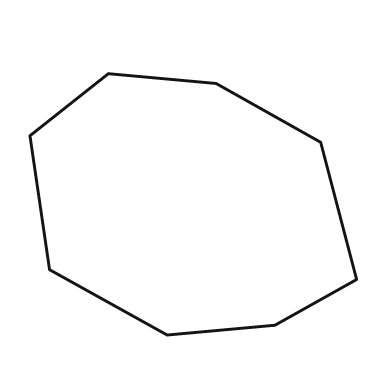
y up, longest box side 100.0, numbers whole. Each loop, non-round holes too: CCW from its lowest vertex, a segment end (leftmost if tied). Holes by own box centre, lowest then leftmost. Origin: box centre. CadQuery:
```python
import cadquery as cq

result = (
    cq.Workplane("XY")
    .moveTo(-8.0, -40.0)
    .lineTo(25.0, -37.0)
    .lineTo(50.0, -23.0)
    .lineTo(39.0, 19.0)
    .lineTo(7.0, 37.0)
    .lineTo(-26.0, 40.0)
    .lineTo(-50.0, 21.0)
    .lineTo(-44.0, -20.0)
    .close()
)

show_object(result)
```